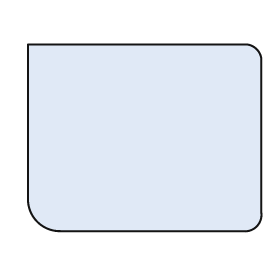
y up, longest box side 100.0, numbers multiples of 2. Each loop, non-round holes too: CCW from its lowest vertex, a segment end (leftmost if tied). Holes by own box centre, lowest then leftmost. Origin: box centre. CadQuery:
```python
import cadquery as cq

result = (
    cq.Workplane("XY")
    .moveTo(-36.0, -40.0)
    .lineTo(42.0, -40.0)
    .threePointArc((48.0, -38.0), (50.0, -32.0))
    .lineTo(50.0, 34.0)
    .threePointArc((48.0, 38.0), (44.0, 40.0))
    .lineTo(-50.0, 40.0)
    .lineTo(-50.0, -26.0)
    .threePointArc((-46.0, -36.0), (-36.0, -40.0))
    .close()
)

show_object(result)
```